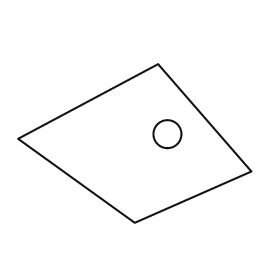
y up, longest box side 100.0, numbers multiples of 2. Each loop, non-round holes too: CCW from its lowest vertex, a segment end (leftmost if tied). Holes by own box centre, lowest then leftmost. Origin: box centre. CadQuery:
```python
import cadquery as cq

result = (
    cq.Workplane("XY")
    .moveTo(0.0, -34.0)
    .lineTo(50.0, -12.0)
    .lineTo(10.0, 34.0)
    .lineTo(-50.0, 2.0)
    .close()
    .moveTo(14.0, 4.0)
    .circle(6.0)
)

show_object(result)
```